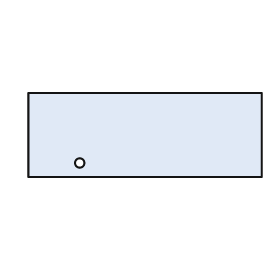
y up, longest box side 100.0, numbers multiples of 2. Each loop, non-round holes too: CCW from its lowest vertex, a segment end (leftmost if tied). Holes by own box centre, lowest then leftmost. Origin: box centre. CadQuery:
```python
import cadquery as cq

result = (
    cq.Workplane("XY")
    .moveTo(-50.0, -18.0)
    .lineTo(50.0, -18.0)
    .lineTo(50.0, 18.0)
    .lineTo(-50.0, 18.0)
    .close()
    .moveTo(-28.0, -12.0)
    .circle(2.0)
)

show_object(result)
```